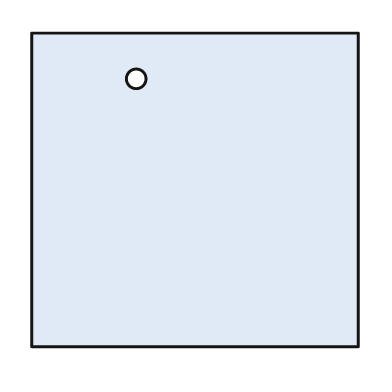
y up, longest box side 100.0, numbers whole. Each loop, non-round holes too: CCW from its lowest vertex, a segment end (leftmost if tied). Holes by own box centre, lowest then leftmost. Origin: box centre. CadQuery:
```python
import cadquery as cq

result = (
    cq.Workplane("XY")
    .moveTo(-50.0, -48.0)
    .lineTo(50.0, -48.0)
    .lineTo(50.0, 48.0)
    .lineTo(-50.0, 48.0)
    .close()
    .moveTo(-18.0, 34.0)
    .circle(3.0)
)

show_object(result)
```